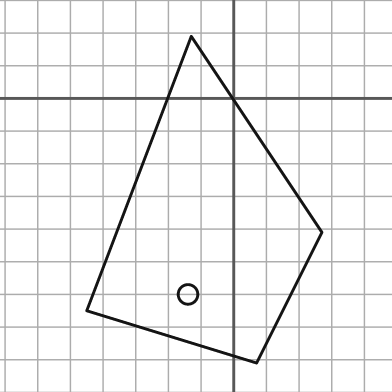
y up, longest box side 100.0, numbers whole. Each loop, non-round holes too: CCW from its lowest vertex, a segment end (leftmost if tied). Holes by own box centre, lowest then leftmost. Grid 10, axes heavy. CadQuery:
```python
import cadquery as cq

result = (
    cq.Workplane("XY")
    .moveTo(7.0, -81.0)
    .lineTo(27.0, -41.0)
    .lineTo(-13.0, 19.0)
    .lineTo(-45.0, -65.0)
    .close()
    .moveTo(-14.0, -60.0)
    .circle(3.0)
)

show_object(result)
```